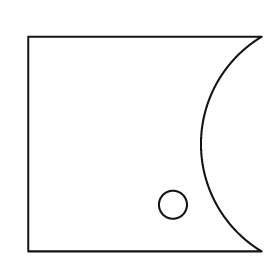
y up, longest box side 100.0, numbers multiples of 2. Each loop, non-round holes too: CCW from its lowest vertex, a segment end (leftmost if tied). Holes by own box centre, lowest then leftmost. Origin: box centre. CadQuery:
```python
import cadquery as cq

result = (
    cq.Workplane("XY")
    .moveTo(-50.0, -46.0)
    .lineTo(50.0, -46.0)
    .threePointArc((24.0, 0.0), (50.0, 46.0))
    .lineTo(-50.0, 46.0)
    .close()
    .moveTo(12.0, -26.0)
    .circle(6.0)
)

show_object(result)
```